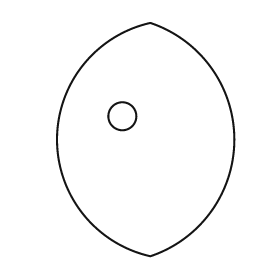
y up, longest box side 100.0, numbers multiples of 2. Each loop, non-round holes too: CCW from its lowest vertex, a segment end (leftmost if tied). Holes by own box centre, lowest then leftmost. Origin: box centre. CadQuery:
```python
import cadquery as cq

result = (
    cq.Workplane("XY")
    .moveTo(2.0, -50.0)
    .threePointArc((38.0, 0.0), (2.0, 50.0))
    .threePointArc((-38.0, 0.0), (2.0, -50.0))
    .close()
    .moveTo(-10.0, 10.0)
    .circle(6.0)
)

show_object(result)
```